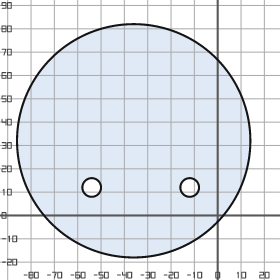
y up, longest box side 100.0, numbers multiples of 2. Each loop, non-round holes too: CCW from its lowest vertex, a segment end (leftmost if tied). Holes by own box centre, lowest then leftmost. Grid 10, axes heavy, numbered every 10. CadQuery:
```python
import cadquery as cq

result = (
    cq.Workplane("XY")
    .moveTo(-36.0, 32.0)
    .circle(50.0)
    .moveTo(-54.0, 12.0)
    .circle(4.0)
    .moveTo(-12.0, 12.0)
    .circle(4.0)
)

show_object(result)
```